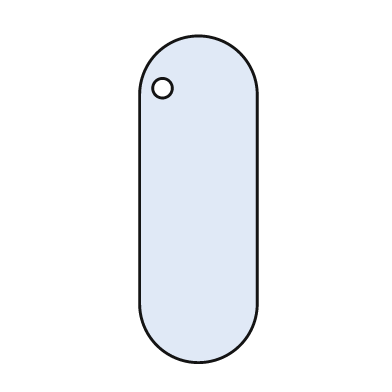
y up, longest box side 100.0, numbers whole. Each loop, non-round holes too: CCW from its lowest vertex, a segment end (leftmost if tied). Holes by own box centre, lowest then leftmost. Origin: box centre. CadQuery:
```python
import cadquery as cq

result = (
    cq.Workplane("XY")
    .moveTo(-18.0, -32.0)
    .threePointArc((0.0, -50.0), (18.0, -32.0))
    .lineTo(18.0, 32.0)
    .threePointArc((0.0, 50.0), (-18.0, 32.0))
    .close()
    .moveTo(-11.0, 34.0)
    .circle(3.0)
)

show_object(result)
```